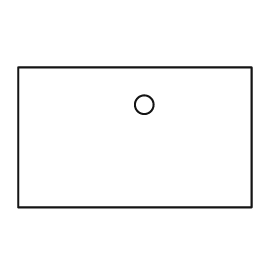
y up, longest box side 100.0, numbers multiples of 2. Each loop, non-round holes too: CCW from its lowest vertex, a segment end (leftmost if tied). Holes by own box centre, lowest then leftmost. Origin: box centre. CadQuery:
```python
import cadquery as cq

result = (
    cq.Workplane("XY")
    .moveTo(-50.0, -30.0)
    .lineTo(50.0, -30.0)
    .lineTo(50.0, 30.0)
    .lineTo(-50.0, 30.0)
    .close()
    .moveTo(4.0, 14.0)
    .circle(4.0)
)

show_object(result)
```